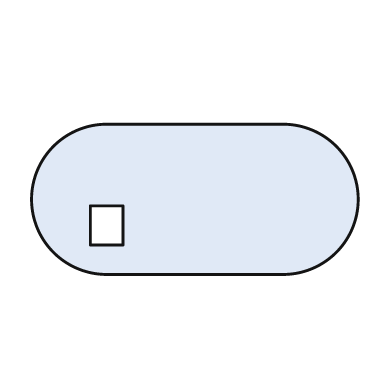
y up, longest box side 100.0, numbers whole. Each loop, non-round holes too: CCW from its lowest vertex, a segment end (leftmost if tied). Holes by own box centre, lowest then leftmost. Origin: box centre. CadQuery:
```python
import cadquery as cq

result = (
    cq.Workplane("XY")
    .moveTo(-27.0, -23.0)
    .lineTo(27.0, -23.0)
    .threePointArc((50.0, 0.0), (27.0, 23.0))
    .lineTo(-27.0, 23.0)
    .threePointArc((-50.0, 0.0), (-27.0, -23.0))
    .close()
    .moveTo(-32.0, -14.0)
    .lineTo(-22.0, -14.0)
    .lineTo(-22.0, -2.0)
    .lineTo(-32.0, -2.0)
    .close()
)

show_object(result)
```